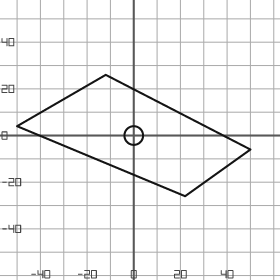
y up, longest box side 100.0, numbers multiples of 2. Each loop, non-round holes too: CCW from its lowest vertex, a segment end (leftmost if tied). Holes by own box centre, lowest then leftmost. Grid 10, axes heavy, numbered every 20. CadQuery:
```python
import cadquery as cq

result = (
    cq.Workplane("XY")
    .moveTo(22.0, -26.0)
    .lineTo(50.0, -6.0)
    .lineTo(-12.0, 26.0)
    .lineTo(-50.0, 4.0)
    .close()
    .moveTo(0.0, 0.0)
    .circle(4.0)
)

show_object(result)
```